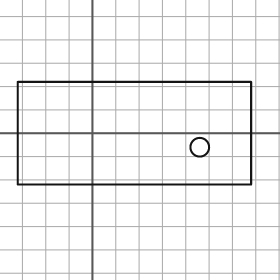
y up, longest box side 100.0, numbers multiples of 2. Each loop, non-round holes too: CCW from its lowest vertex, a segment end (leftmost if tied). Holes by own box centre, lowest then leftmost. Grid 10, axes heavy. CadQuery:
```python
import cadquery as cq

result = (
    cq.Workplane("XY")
    .moveTo(-32.0, -22.0)
    .lineTo(68.0, -22.0)
    .lineTo(68.0, 22.0)
    .lineTo(-32.0, 22.0)
    .close()
    .moveTo(46.0, -6.0)
    .circle(4.0)
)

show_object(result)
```